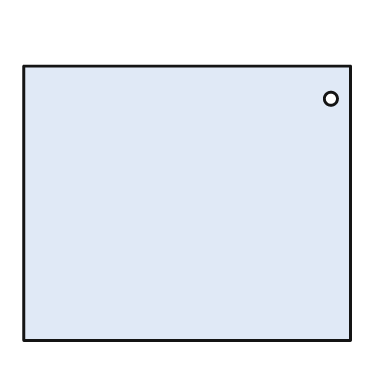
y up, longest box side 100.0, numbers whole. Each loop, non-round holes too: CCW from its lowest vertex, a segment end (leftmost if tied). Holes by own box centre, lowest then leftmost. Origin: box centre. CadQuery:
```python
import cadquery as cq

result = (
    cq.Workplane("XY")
    .moveTo(-50.0, -42.0)
    .lineTo(50.0, -42.0)
    .lineTo(50.0, 42.0)
    .lineTo(-50.0, 42.0)
    .close()
    .moveTo(44.0, 32.0)
    .circle(2.0)
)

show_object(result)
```